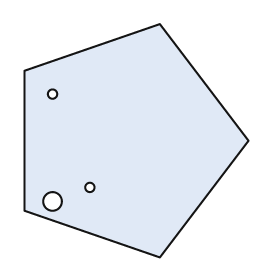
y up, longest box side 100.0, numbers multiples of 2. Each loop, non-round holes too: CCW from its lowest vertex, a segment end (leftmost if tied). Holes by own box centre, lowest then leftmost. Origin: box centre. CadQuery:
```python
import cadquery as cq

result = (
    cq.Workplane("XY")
    .moveTo(10.0, -50.0)
    .lineTo(48.0, 0.0)
    .lineTo(10.0, 50.0)
    .lineTo(-48.0, 30.0)
    .lineTo(-48.0, -30.0)
    .close()
    .moveTo(-36.0, -26.0)
    .circle(4.0)
    .moveTo(-20.0, -20.0)
    .circle(2.0)
    .moveTo(-36.0, 20.0)
    .circle(2.0)
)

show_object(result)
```